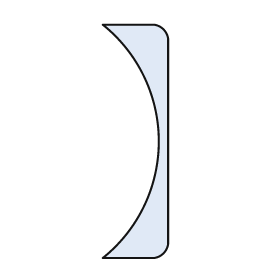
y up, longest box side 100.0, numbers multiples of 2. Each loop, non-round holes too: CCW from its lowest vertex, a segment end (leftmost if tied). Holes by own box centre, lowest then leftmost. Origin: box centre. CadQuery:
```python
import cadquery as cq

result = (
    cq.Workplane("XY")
    .moveTo(-14.0, -50.0)
    .lineTo(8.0, -50.0)
    .threePointArc((12.0, -48.0), (14.0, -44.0))
    .lineTo(14.0, 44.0)
    .threePointArc((12.0, 48.0), (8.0, 50.0))
    .lineTo(-14.0, 50.0)
    .threePointArc((10.0, 0.0), (-14.0, -50.0))
    .close()
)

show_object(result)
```